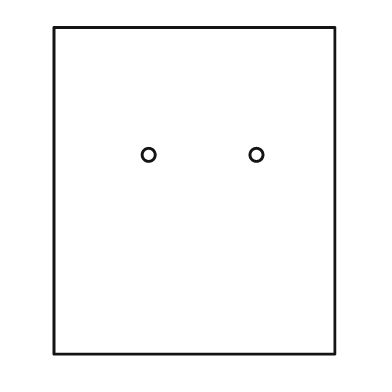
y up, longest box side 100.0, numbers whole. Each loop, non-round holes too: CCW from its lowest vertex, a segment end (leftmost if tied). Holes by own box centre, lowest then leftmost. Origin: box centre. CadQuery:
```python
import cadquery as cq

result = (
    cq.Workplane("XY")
    .moveTo(-43.0, -50.0)
    .lineTo(43.0, -50.0)
    .lineTo(43.0, 50.0)
    .lineTo(-43.0, 50.0)
    .close()
    .moveTo(-14.0, 11.0)
    .circle(2.0)
    .moveTo(19.0, 11.0)
    .circle(2.0)
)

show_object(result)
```